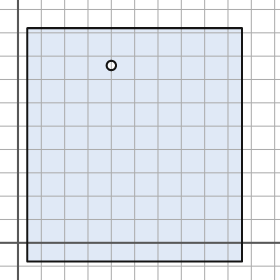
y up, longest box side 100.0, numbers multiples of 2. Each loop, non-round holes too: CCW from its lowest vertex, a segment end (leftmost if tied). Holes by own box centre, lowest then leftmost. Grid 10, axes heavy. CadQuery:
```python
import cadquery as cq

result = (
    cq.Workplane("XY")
    .moveTo(4.0, -8.0)
    .lineTo(96.0, -8.0)
    .lineTo(96.0, 92.0)
    .lineTo(4.0, 92.0)
    .close()
    .moveTo(40.0, 76.0)
    .circle(2.0)
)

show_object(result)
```